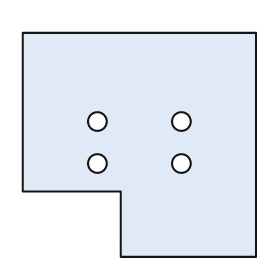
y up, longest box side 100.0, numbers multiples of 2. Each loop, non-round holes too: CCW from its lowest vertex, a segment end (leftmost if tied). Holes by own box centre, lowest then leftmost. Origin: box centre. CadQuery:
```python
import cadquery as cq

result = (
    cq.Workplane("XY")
    .moveTo(-8.0, -48.0)
    .lineTo(50.0, -48.0)
    .lineTo(50.0, 48.0)
    .lineTo(-50.0, 48.0)
    .lineTo(-50.0, -20.0)
    .lineTo(-8.0, -20.0)
    .close()
    .moveTo(-18.0, -8.0)
    .circle(4.0)
    .moveTo(18.0, -8.0)
    .circle(4.0)
    .moveTo(-18.0, 10.0)
    .circle(4.0)
    .moveTo(18.0, 10.0)
    .circle(4.0)
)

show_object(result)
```